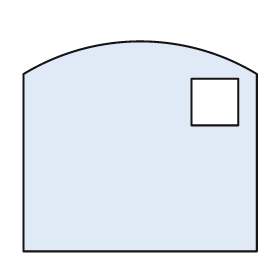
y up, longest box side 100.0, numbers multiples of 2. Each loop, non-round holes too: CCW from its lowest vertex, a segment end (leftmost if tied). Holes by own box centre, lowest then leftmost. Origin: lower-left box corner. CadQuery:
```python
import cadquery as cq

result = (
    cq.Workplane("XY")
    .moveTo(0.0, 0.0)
    .lineTo(100.0, 0.0)
    .lineTo(100.0, 76.0)
    .threePointArc((50.0, 90.0), (0.0, 76.0))
    .close()
    .moveTo(72.0, 54.0)
    .lineTo(92.0, 54.0)
    .lineTo(92.0, 74.0)
    .lineTo(72.0, 74.0)
    .close()
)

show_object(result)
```